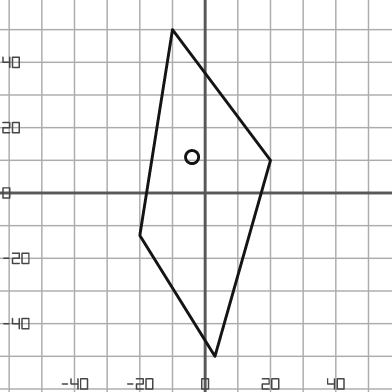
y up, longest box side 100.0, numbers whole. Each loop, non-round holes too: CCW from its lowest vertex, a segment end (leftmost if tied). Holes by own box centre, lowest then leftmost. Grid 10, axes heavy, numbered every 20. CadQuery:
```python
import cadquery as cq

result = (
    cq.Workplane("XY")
    .moveTo(3.0, -50.0)
    .lineTo(20.0, 10.0)
    .lineTo(-10.0, 50.0)
    .lineTo(-20.0, -13.0)
    .close()
    .moveTo(-4.0, 11.0)
    .circle(2.0)
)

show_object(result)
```